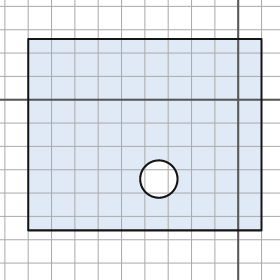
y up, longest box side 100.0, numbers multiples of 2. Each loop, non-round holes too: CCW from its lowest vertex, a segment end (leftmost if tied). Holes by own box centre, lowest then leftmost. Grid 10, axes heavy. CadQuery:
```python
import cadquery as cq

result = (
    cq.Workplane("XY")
    .moveTo(-90.0, -56.0)
    .lineTo(10.0, -56.0)
    .lineTo(10.0, 26.0)
    .lineTo(-90.0, 26.0)
    .close()
    .moveTo(-34.0, -34.0)
    .circle(8.0)
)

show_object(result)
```